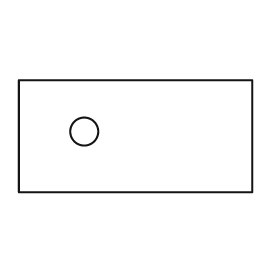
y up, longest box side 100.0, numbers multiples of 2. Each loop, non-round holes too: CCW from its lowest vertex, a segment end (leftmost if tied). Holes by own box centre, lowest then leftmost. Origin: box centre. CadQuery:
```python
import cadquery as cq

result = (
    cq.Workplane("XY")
    .moveTo(-50.0, -24.0)
    .lineTo(50.0, -24.0)
    .lineTo(50.0, 24.0)
    .lineTo(-50.0, 24.0)
    .close()
    .moveTo(-22.0, 2.0)
    .circle(6.0)
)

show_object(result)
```